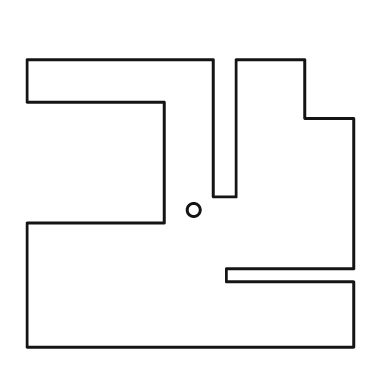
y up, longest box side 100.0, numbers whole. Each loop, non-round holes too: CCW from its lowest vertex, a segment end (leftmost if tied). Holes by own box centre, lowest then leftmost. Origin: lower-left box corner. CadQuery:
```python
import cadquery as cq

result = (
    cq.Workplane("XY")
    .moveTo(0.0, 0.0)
    .lineTo(100.0, 0.0)
    .lineTo(100.0, 20.0)
    .lineTo(61.0, 20.0)
    .lineTo(61.0, 24.0)
    .lineTo(100.0, 24.0)
    .lineTo(100.0, 70.0)
    .lineTo(85.0, 70.0)
    .lineTo(85.0, 88.0)
    .lineTo(64.0, 88.0)
    .lineTo(64.0, 46.0)
    .lineTo(57.0, 46.0)
    .lineTo(57.0, 88.0)
    .lineTo(0.0, 88.0)
    .lineTo(0.0, 75.0)
    .lineTo(42.0, 75.0)
    .lineTo(42.0, 38.0)
    .lineTo(0.0, 38.0)
    .close()
    .moveTo(51.0, 42.0)
    .circle(2.0)
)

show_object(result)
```